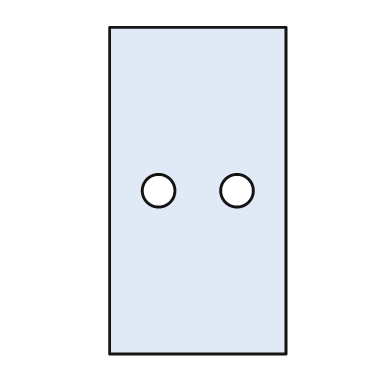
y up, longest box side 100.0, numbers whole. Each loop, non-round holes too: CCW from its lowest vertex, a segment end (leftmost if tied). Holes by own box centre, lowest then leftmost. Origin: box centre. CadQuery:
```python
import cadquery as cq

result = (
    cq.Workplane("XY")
    .moveTo(-27.0, -50.0)
    .lineTo(27.0, -50.0)
    .lineTo(27.0, 50.0)
    .lineTo(-27.0, 50.0)
    .close()
    .moveTo(-12.0, 0.0)
    .circle(5.0)
    .moveTo(12.0, 0.0)
    .circle(5.0)
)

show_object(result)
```